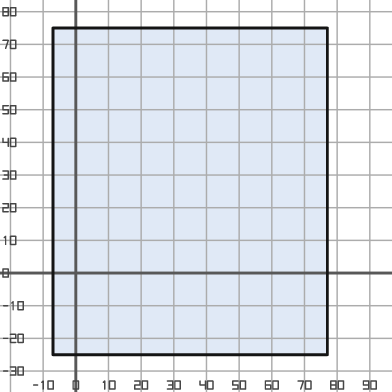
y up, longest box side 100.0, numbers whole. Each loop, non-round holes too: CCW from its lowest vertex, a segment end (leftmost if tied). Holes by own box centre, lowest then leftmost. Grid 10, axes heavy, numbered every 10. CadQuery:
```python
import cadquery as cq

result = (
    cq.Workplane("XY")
    .moveTo(-7.0, -25.0)
    .lineTo(77.0, -25.0)
    .lineTo(77.0, 75.0)
    .lineTo(-7.0, 75.0)
    .close()
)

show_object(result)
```